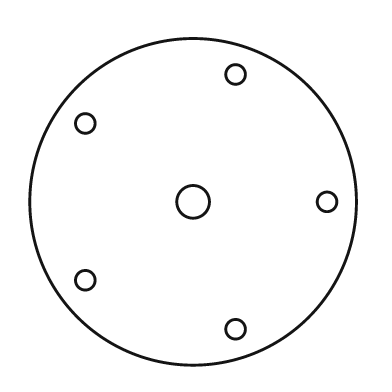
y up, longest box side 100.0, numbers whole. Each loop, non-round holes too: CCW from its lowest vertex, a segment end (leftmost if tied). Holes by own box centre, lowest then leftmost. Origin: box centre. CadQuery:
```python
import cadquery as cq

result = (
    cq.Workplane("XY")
    .moveTo(0.0, 0.0)
    .circle(50.0)
    .moveTo(13.0, -39.0)
    .circle(3.0)
    .moveTo(-33.0, -24.0)
    .circle(3.0)
    .moveTo(0.0, 0.0)
    .circle(5.0)
    .moveTo(41.0, 0.0)
    .circle(3.0)
    .moveTo(-33.0, 24.0)
    .circle(3.0)
    .moveTo(13.0, 39.0)
    .circle(3.0)
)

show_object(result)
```